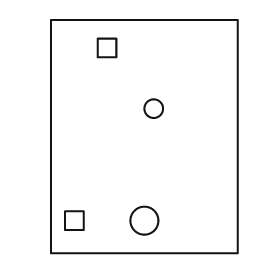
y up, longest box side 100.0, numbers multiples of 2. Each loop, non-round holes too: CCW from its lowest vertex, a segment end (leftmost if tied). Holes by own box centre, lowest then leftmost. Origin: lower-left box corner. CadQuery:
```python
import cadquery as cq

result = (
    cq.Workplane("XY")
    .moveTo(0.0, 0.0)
    .lineTo(80.0, 0.0)
    .lineTo(80.0, 100.0)
    .lineTo(0.0, 100.0)
    .close()
    .moveTo(6.0, 10.0)
    .lineTo(14.0, 10.0)
    .lineTo(14.0, 18.0)
    .lineTo(6.0, 18.0)
    .close()
    .moveTo(40.0, 14.0)
    .circle(6.0)
    .moveTo(44.0, 62.0)
    .circle(4.0)
    .moveTo(20.0, 84.0)
    .lineTo(28.0, 84.0)
    .lineTo(28.0, 92.0)
    .lineTo(20.0, 92.0)
    .close()
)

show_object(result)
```